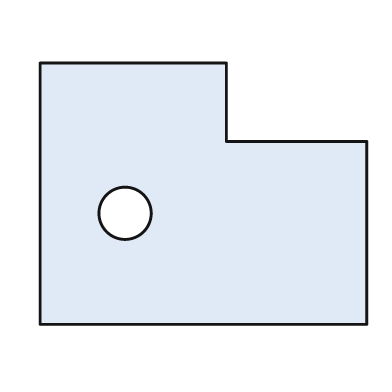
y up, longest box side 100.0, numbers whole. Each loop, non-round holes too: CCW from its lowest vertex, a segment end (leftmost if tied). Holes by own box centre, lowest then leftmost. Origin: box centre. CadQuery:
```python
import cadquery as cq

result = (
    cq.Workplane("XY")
    .moveTo(-50.0, -40.0)
    .lineTo(50.0, -40.0)
    .lineTo(50.0, 16.0)
    .lineTo(7.0, 16.0)
    .lineTo(7.0, 40.0)
    .lineTo(-50.0, 40.0)
    .close()
    .moveTo(-24.0, -6.0)
    .circle(8.0)
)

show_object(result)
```